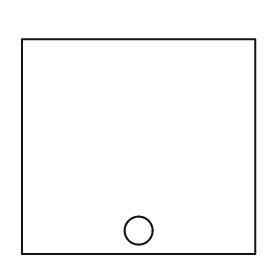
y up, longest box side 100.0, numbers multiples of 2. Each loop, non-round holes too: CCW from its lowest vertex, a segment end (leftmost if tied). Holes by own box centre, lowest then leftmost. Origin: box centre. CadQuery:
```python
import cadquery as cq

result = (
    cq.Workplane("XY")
    .moveTo(-50.0, -46.0)
    .lineTo(50.0, -46.0)
    .lineTo(50.0, 46.0)
    .lineTo(-50.0, 46.0)
    .close()
    .moveTo(0.0, -36.0)
    .circle(6.0)
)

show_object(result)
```